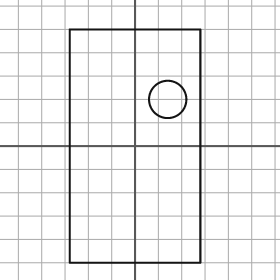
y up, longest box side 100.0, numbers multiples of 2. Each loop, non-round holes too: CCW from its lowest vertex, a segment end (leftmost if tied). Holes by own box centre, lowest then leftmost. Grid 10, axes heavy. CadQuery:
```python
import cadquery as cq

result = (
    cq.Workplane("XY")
    .moveTo(-28.0, -50.0)
    .lineTo(28.0, -50.0)
    .lineTo(28.0, 50.0)
    .lineTo(-28.0, 50.0)
    .close()
    .moveTo(14.0, 20.0)
    .circle(8.0)
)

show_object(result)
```